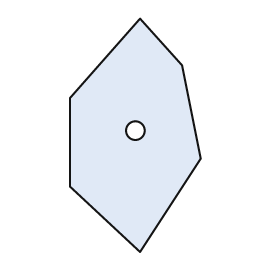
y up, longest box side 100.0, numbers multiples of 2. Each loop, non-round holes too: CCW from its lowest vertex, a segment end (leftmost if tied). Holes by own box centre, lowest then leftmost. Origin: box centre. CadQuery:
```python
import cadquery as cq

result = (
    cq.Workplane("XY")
    .moveTo(2.0, -50.0)
    .lineTo(28.0, -10.0)
    .lineTo(20.0, 30.0)
    .lineTo(2.0, 50.0)
    .lineTo(-28.0, 16.0)
    .lineTo(-28.0, -22.0)
    .close()
    .moveTo(0.0, 2.0)
    .circle(4.0)
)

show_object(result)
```